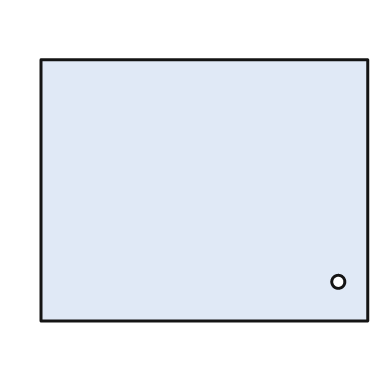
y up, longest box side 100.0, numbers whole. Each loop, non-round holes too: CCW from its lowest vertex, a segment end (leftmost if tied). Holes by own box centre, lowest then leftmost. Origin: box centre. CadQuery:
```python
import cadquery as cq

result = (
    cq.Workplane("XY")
    .moveTo(-50.0, -40.0)
    .lineTo(50.0, -40.0)
    .lineTo(50.0, 40.0)
    .lineTo(-50.0, 40.0)
    .close()
    .moveTo(41.0, -28.0)
    .circle(2.0)
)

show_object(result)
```